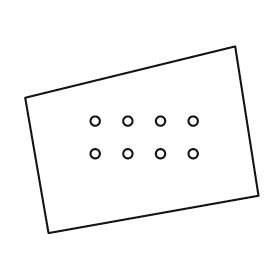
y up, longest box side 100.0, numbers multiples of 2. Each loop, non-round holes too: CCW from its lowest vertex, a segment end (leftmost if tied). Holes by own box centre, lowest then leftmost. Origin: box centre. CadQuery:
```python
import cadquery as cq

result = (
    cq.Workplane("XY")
    .moveTo(-40.0, -40.0)
    .lineTo(50.0, -24.0)
    .lineTo(40.0, 40.0)
    .lineTo(-50.0, 18.0)
    .close()
    .moveTo(-20.0, -6.0)
    .circle(2.0)
    .moveTo(-6.0, -6.0)
    .circle(2.0)
    .moveTo(8.0, -6.0)
    .circle(2.0)
    .moveTo(22.0, -6.0)
    .circle(2.0)
    .moveTo(-20.0, 8.0)
    .circle(2.0)
    .moveTo(-6.0, 8.0)
    .circle(2.0)
    .moveTo(8.0, 8.0)
    .circle(2.0)
    .moveTo(22.0, 8.0)
    .circle(2.0)
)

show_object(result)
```